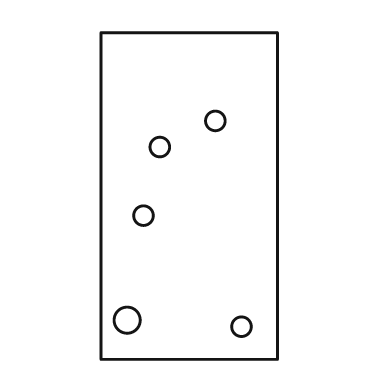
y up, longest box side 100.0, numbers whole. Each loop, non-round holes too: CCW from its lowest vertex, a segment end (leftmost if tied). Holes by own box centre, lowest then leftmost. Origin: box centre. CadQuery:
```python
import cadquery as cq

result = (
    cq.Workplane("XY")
    .moveTo(-27.0, -50.0)
    .lineTo(27.0, -50.0)
    .lineTo(27.0, 50.0)
    .lineTo(-27.0, 50.0)
    .close()
    .moveTo(16.0, -40.0)
    .circle(3.0)
    .moveTo(-19.0, -38.0)
    .circle(4.0)
    .moveTo(-14.0, -6.0)
    .circle(3.0)
    .moveTo(-9.0, 15.0)
    .circle(3.0)
    .moveTo(8.0, 23.0)
    .circle(3.0)
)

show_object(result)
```